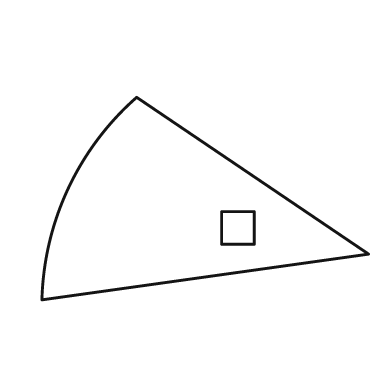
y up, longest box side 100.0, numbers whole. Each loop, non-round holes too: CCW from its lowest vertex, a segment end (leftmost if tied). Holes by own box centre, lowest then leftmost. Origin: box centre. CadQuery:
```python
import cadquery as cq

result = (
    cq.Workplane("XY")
    .moveTo(-50.0, -31.0)
    .lineTo(50.0, -17.0)
    .lineTo(-21.0, 31.0)
    .threePointArc((-42.0, 3.0), (-50.0, -31.0))
    .close()
    .moveTo(5.0, -14.0)
    .lineTo(15.0, -14.0)
    .lineTo(15.0, -4.0)
    .lineTo(5.0, -4.0)
    .close()
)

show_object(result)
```